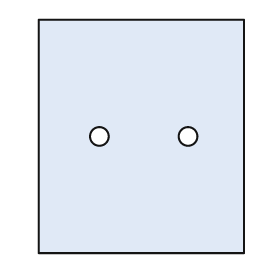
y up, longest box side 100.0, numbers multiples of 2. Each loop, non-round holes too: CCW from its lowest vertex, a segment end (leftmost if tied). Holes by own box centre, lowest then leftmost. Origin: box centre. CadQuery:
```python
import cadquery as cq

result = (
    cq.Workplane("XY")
    .moveTo(-44.0, -50.0)
    .lineTo(44.0, -50.0)
    .lineTo(44.0, 50.0)
    .lineTo(-44.0, 50.0)
    .close()
    .moveTo(-18.0, 0.0)
    .circle(4.0)
    .moveTo(20.0, 0.0)
    .circle(4.0)
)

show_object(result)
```